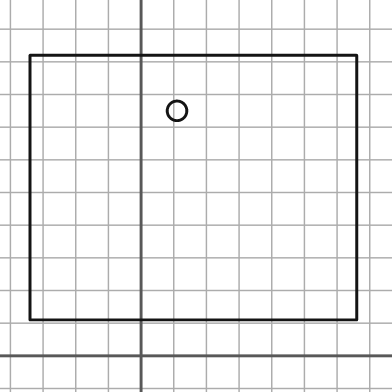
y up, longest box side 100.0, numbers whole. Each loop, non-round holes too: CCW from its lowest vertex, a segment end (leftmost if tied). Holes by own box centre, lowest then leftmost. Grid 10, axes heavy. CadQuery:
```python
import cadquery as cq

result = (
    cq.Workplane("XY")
    .moveTo(-34.0, 11.0)
    .lineTo(66.0, 11.0)
    .lineTo(66.0, 92.0)
    .lineTo(-34.0, 92.0)
    .close()
    .moveTo(11.0, 75.0)
    .circle(3.0)
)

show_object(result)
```